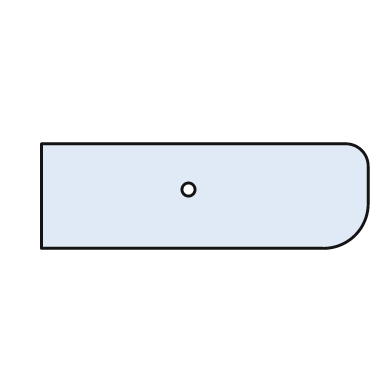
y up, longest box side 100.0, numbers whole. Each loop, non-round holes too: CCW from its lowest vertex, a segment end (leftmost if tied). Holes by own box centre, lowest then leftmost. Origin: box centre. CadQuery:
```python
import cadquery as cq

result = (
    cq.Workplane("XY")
    .moveTo(-50.0, -16.0)
    .lineTo(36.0, -16.0)
    .threePointArc((46.0, -12.0), (50.0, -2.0))
    .lineTo(50.0, 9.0)
    .threePointArc((48.0, 14.0), (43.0, 16.0))
    .lineTo(-50.0, 16.0)
    .close()
    .moveTo(-5.0, 2.0)
    .circle(2.0)
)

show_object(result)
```